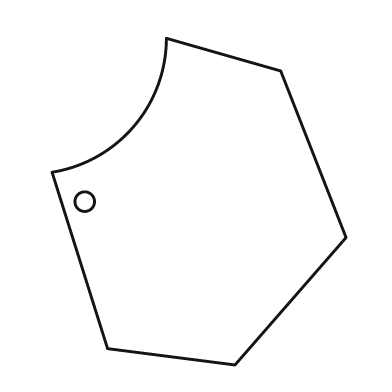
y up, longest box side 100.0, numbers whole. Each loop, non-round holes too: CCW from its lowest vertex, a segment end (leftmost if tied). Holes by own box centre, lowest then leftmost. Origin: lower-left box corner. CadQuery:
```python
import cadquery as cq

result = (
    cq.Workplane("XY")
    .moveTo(56.0, 0.0)
    .lineTo(90.0, 39.0)
    .lineTo(70.0, 90.0)
    .lineTo(35.0, 100.0)
    .threePointArc((25.0, 73.0), (0.0, 59.0))
    .lineTo(17.0, 5.0)
    .close()
    .moveTo(10.0, 50.0)
    .circle(3.0)
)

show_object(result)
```